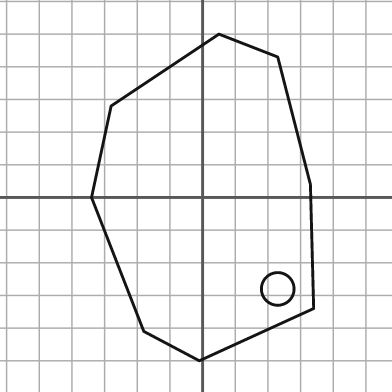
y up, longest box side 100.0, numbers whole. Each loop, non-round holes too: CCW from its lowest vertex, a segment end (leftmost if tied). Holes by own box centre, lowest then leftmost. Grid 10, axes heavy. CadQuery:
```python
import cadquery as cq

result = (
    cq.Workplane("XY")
    .moveTo(-1.0, -50.0)
    .lineTo(34.0, -34.0)
    .lineTo(33.0, 4.0)
    .lineTo(23.0, 43.0)
    .lineTo(5.0, 50.0)
    .lineTo(-28.0, 28.0)
    .lineTo(-34.0, 0.0)
    .lineTo(-18.0, -41.0)
    .close()
    .moveTo(23.0, -28.0)
    .circle(5.0)
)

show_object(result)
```